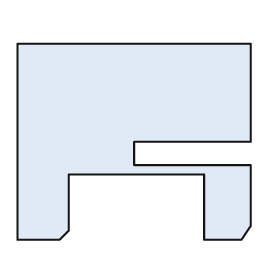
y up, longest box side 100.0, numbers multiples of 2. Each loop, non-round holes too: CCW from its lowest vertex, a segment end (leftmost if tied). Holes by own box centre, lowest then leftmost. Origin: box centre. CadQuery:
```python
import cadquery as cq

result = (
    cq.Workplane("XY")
    .moveTo(-50.0, -42.0)
    .lineTo(-32.0, -42.0)
    .lineTo(-28.0, -38.0)
    .lineTo(-28.0, -14.0)
    .lineTo(30.0, -14.0)
    .lineTo(30.0, -42.0)
    .lineTo(46.0, -42.0)
    .lineTo(50.0, -36.0)
    .lineTo(50.0, -10.0)
    .lineTo(0.0, -10.0)
    .lineTo(0.0, 0.0)
    .lineTo(50.0, 0.0)
    .lineTo(50.0, 42.0)
    .lineTo(-50.0, 42.0)
    .close()
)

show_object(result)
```